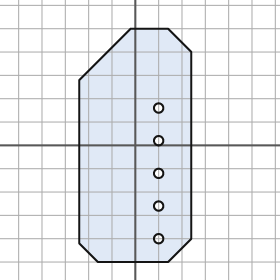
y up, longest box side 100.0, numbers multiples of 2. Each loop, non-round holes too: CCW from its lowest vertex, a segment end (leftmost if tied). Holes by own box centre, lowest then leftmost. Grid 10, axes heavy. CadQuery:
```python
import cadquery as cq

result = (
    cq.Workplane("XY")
    .moveTo(-16.0, -50.0)
    .lineTo(14.0, -50.0)
    .lineTo(24.0, -40.0)
    .lineTo(24.0, 40.0)
    .lineTo(14.0, 50.0)
    .lineTo(-2.0, 50.0)
    .lineTo(-24.0, 28.0)
    .lineTo(-24.0, -42.0)
    .close()
    .moveTo(10.0, -40.0)
    .circle(2.0)
    .moveTo(10.0, -26.0)
    .circle(2.0)
    .moveTo(10.0, -12.0)
    .circle(2.0)
    .moveTo(10.0, 2.0)
    .circle(2.0)
    .moveTo(10.0, 16.0)
    .circle(2.0)
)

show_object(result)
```